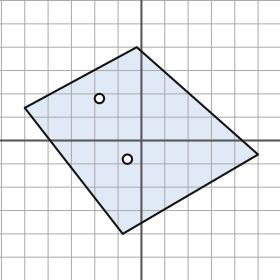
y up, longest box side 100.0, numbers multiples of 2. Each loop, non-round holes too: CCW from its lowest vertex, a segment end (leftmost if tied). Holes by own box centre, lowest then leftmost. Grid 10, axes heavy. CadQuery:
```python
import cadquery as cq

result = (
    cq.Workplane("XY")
    .moveTo(-8.0, -40.0)
    .lineTo(50.0, -6.0)
    .lineTo(-2.0, 40.0)
    .lineTo(-50.0, 14.0)
    .close()
    .moveTo(-6.0, -8.0)
    .circle(2.0)
    .moveTo(-18.0, 18.0)
    .circle(2.0)
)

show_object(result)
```